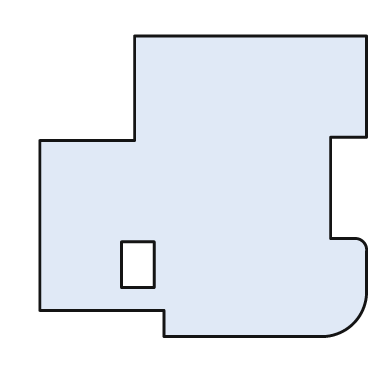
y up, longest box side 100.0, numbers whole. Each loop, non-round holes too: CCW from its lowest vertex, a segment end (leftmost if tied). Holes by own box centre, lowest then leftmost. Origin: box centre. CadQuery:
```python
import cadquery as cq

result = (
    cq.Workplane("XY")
    .moveTo(-12.0, -46.0)
    .lineTo(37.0, -46.0)
    .threePointArc((46.0, -42.0), (50.0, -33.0))
    .lineTo(50.0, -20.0)
    .threePointArc((49.0, -17.0), (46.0, -16.0))
    .lineTo(39.0, -16.0)
    .lineTo(39.0, 15.0)
    .lineTo(50.0, 15.0)
    .lineTo(50.0, 46.0)
    .lineTo(-21.0, 46.0)
    .lineTo(-21.0, 14.0)
    .lineTo(-50.0, 14.0)
    .lineTo(-50.0, -38.0)
    .lineTo(-12.0, -38.0)
    .close()
    .moveTo(-25.0, -31.0)
    .lineTo(-15.0, -31.0)
    .lineTo(-15.0, -17.0)
    .lineTo(-25.0, -17.0)
    .close()
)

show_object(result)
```